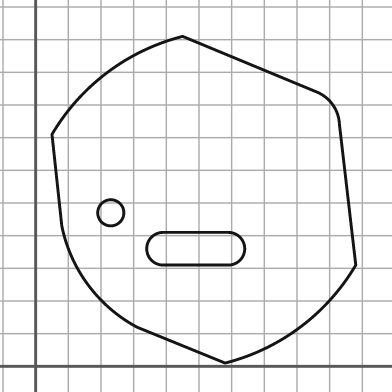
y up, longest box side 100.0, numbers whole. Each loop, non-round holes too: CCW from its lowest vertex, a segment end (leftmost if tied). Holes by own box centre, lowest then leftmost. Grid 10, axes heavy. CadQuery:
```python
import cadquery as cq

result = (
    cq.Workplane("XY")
    .moveTo(58.0, 1.0)
    .threePointArc((81.0, 12.0), (98.0, 31.0))
    .lineTo(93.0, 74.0)
    .threePointArc((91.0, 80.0), (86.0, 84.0))
    .lineTo(45.0, 101.0)
    .threePointArc((22.0, 90.0), (5.0, 71.0))
    .lineTo(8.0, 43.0)
    .threePointArc((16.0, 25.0), (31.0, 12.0))
    .close()
    .moveTo(39.0, 31.0)
    .lineTo(59.0, 31.0)
    .threePointArc((64.0, 36.0), (59.0, 41.0))
    .lineTo(39.0, 41.0)
    .threePointArc((34.0, 36.0), (39.0, 31.0))
    .close()
    .moveTo(23.0, 47.0)
    .circle(4.0)
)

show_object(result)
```